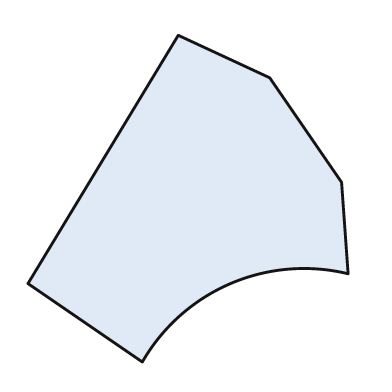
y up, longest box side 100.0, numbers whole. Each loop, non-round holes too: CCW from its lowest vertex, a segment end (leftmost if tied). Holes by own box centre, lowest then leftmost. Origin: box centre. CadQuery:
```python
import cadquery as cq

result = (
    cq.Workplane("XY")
    .moveTo(-14.0, -50.0)
    .threePointArc((13.0, -26.0), (49.0, -23.0))
    .lineTo(47.0, 5.0)
    .lineTo(25.0, 37.0)
    .lineTo(-3.0, 50.0)
    .lineTo(-49.0, -26.0)
    .close()
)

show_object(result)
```